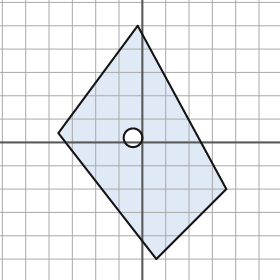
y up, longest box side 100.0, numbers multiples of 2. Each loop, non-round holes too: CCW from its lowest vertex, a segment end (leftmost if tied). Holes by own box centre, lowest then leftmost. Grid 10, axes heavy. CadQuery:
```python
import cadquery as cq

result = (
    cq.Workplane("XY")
    .moveTo(6.0, -50.0)
    .lineTo(36.0, -20.0)
    .lineTo(-2.0, 50.0)
    .lineTo(-36.0, 4.0)
    .close()
    .moveTo(-4.0, 2.0)
    .circle(4.0)
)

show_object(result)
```